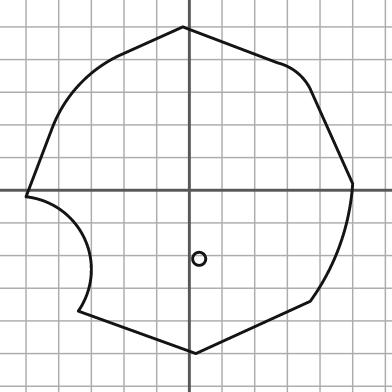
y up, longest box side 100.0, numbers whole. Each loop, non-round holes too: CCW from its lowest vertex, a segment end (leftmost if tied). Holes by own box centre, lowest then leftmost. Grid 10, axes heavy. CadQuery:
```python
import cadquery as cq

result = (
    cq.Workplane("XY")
    .moveTo(2.0, -50.0)
    .lineTo(37.0, -34.0)
    .threePointArc((46.0, -17.0), (50.0, 2.0))
    .lineTo(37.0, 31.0)
    .threePointArc((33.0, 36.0), (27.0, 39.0))
    .lineTo(-2.0, 50.0)
    .lineTo(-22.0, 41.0)
    .threePointArc((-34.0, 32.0), (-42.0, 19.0))
    .lineTo(-50.0, -2.0)
    .threePointArc((-32.0, -15.0), (-34.0, -37.0))
    .close()
    .moveTo(3.0, -21.0)
    .circle(2.0)
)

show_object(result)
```